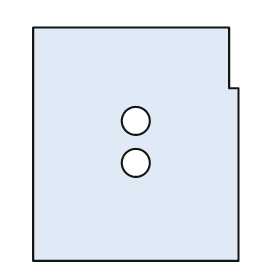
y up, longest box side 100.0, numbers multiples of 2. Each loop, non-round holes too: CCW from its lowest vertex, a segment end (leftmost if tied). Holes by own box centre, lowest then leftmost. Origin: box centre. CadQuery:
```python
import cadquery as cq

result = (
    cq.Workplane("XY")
    .moveTo(-44.0, -50.0)
    .lineTo(44.0, -50.0)
    .lineTo(44.0, 24.0)
    .lineTo(40.0, 24.0)
    .lineTo(40.0, 50.0)
    .lineTo(-44.0, 50.0)
    .close()
    .moveTo(0.0, -8.0)
    .circle(6.0)
    .moveTo(0.0, 10.0)
    .circle(6.0)
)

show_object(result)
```